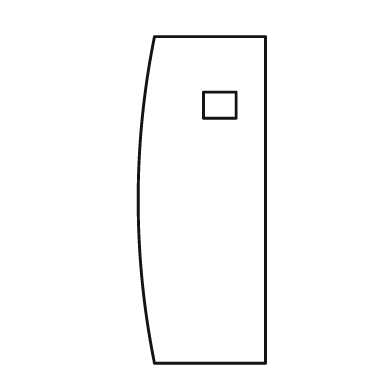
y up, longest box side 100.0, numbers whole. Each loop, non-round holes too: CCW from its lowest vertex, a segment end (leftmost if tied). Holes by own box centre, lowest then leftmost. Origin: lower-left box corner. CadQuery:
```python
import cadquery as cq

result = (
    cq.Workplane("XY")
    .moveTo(5.0, 0.0)
    .lineTo(39.0, 0.0)
    .lineTo(39.0, 100.0)
    .lineTo(5.0, 100.0)
    .threePointArc((0.0, 50.0), (5.0, 0.0))
    .close()
    .moveTo(20.0, 75.0)
    .lineTo(30.0, 75.0)
    .lineTo(30.0, 83.0)
    .lineTo(20.0, 83.0)
    .close()
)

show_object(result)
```